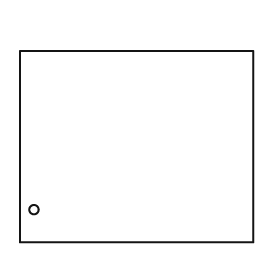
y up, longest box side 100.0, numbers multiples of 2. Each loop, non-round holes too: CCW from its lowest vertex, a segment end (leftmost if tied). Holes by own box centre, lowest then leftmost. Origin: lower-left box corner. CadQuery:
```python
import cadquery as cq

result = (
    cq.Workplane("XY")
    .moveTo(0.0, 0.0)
    .lineTo(100.0, 0.0)
    .lineTo(100.0, 82.0)
    .lineTo(0.0, 82.0)
    .close()
    .moveTo(6.0, 14.0)
    .circle(2.0)
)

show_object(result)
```